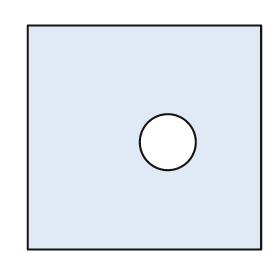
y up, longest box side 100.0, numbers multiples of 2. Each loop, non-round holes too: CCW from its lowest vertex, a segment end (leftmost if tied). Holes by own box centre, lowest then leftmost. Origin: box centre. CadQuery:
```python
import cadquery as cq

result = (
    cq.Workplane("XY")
    .moveTo(-50.0, -48.0)
    .lineTo(50.0, -48.0)
    .lineTo(50.0, 48.0)
    .lineTo(-50.0, 48.0)
    .close()
    .moveTo(10.0, -2.0)
    .circle(12.0)
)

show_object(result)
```